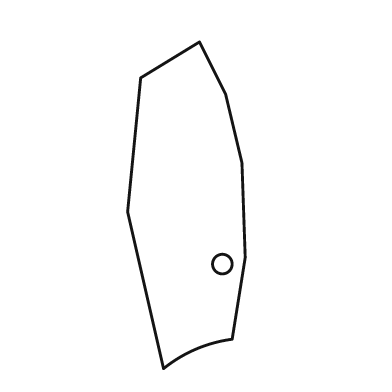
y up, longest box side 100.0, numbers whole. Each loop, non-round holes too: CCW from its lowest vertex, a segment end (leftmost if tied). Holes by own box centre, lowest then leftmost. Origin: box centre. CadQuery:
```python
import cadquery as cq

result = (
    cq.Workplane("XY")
    .moveTo(-7.0, -50.0)
    .threePointArc((3.0, -44.0), (14.0, -41.0))
    .lineTo(18.0, -16.0)
    .lineTo(17.0, 13.0)
    .lineTo(12.0, 34.0)
    .lineTo(4.0, 50.0)
    .lineTo(-14.0, 39.0)
    .lineTo(-18.0, -2.0)
    .close()
    .moveTo(11.0, -18.0)
    .circle(3.0)
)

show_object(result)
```